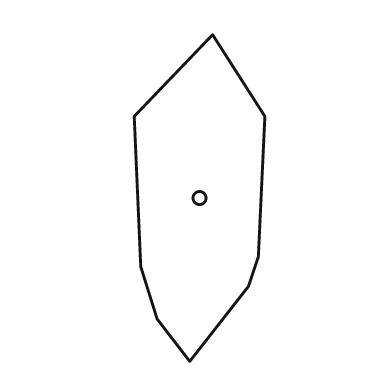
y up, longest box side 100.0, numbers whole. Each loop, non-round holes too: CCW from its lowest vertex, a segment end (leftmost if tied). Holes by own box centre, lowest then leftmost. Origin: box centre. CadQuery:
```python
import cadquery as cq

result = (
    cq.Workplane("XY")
    .moveTo(-3.0, -50.0)
    .lineTo(15.0, -27.0)
    .lineTo(18.0, -18.0)
    .lineTo(20.0, 25.0)
    .lineTo(4.0, 50.0)
    .lineTo(-20.0, 25.0)
    .lineTo(-18.0, -21.0)
    .lineTo(-13.0, -37.0)
    .close()
    .moveTo(0.0, 0.0)
    .circle(2.0)
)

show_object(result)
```